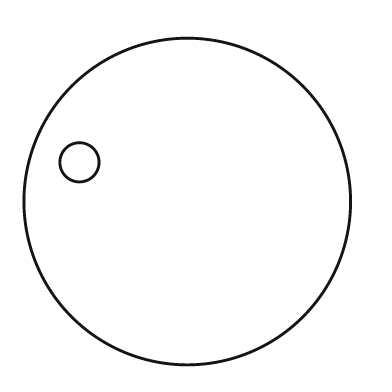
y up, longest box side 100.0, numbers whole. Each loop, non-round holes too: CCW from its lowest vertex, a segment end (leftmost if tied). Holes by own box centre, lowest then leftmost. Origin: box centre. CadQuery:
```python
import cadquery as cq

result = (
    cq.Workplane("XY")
    .moveTo(0.0, 0.0)
    .circle(50.0)
    .moveTo(-33.0, 12.0)
    .circle(6.0)
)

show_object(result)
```